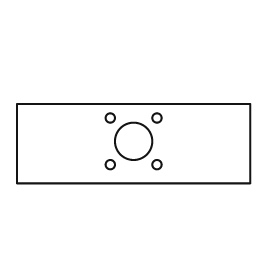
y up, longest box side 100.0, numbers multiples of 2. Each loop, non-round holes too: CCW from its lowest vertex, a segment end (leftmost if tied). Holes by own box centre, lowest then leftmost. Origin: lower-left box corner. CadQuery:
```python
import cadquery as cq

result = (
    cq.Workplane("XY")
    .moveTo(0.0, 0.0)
    .lineTo(100.0, 0.0)
    .lineTo(100.0, 34.0)
    .lineTo(0.0, 34.0)
    .close()
    .moveTo(40.0, 8.0)
    .circle(2.0)
    .moveTo(60.0, 8.0)
    .circle(2.0)
    .moveTo(50.0, 18.0)
    .circle(8.0)
    .moveTo(40.0, 28.0)
    .circle(2.0)
    .moveTo(60.0, 28.0)
    .circle(2.0)
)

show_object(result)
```